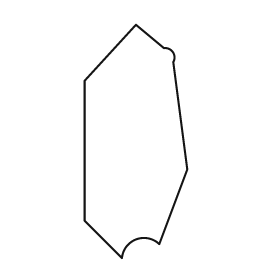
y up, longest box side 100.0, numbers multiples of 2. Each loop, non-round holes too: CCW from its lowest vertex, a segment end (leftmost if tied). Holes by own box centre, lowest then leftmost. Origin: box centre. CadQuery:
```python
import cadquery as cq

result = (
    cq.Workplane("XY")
    .moveTo(-6.0, -50.0)
    .threePointArc((0.0, -42.0), (10.0, -44.0))
    .lineTo(22.0, -12.0)
    .lineTo(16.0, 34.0)
    .threePointArc((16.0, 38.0), (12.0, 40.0))
    .lineTo(0.0, 50.0)
    .lineTo(-22.0, 26.0)
    .lineTo(-22.0, -34.0)
    .close()
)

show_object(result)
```